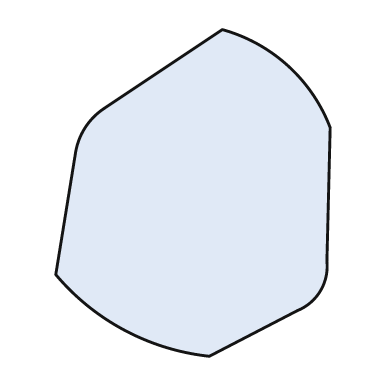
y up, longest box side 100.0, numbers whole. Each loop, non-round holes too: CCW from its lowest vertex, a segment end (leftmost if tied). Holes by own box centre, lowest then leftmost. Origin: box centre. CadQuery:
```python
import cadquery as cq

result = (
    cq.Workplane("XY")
    .moveTo(5.0, -50.0)
    .lineTo(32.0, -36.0)
    .threePointArc((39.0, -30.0), (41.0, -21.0))
    .lineTo(42.0, 20.0)
    .threePointArc((29.0, 39.0), (9.0, 50.0))
    .lineTo(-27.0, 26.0)
    .threePointArc((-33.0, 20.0), (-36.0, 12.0))
    .lineTo(-42.0, -25.0)
    .threePointArc((-21.0, -42.0), (5.0, -50.0))
    .close()
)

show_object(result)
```